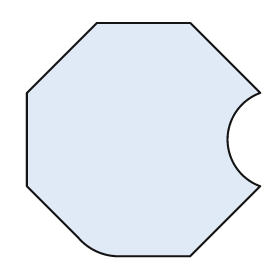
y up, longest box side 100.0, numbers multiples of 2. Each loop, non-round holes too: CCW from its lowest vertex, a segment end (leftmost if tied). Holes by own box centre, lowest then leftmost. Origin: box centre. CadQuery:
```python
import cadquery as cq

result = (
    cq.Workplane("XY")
    .moveTo(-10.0, -50.0)
    .lineTo(20.0, -50.0)
    .lineTo(50.0, -20.0)
    .threePointArc((36.0, 0.0), (50.0, 20.0))
    .lineTo(20.0, 50.0)
    .lineTo(-20.0, 50.0)
    .lineTo(-50.0, 20.0)
    .lineTo(-50.0, -20.0)
    .lineTo(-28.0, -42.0)
    .threePointArc((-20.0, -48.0), (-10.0, -50.0))
    .close()
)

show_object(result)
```